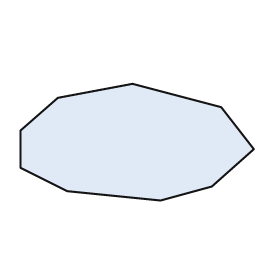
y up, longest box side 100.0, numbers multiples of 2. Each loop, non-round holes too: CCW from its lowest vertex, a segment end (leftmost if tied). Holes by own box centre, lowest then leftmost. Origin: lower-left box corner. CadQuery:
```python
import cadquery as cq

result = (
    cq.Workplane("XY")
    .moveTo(60.0, 0.0)
    .lineTo(82.0, 6.0)
    .lineTo(100.0, 22.0)
    .lineTo(86.0, 40.0)
    .lineTo(48.0, 50.0)
    .lineTo(16.0, 44.0)
    .lineTo(0.0, 30.0)
    .lineTo(0.0, 14.0)
    .lineTo(20.0, 4.0)
    .close()
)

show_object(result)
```